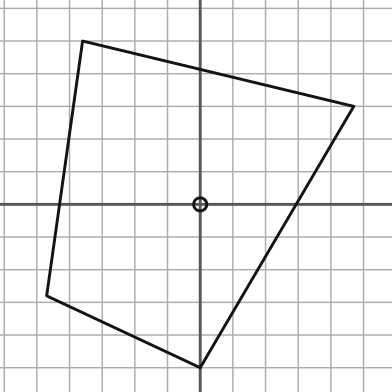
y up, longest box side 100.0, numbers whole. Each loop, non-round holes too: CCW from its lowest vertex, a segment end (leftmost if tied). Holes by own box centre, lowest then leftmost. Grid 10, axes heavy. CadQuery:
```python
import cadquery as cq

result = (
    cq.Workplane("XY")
    .moveTo(0.0, -50.0)
    .lineTo(47.0, 30.0)
    .lineTo(-36.0, 50.0)
    .lineTo(-47.0, -28.0)
    .close()
    .moveTo(0.0, 0.0)
    .circle(2.0)
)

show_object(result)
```